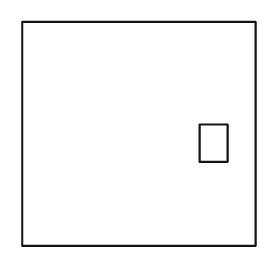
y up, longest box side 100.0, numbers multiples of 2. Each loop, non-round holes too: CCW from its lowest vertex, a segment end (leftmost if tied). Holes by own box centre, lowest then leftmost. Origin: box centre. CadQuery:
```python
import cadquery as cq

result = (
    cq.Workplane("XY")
    .moveTo(-50.0, -48.0)
    .lineTo(50.0, -48.0)
    .lineTo(50.0, 48.0)
    .lineTo(-50.0, 48.0)
    .close()
    .moveTo(26.0, -12.0)
    .lineTo(38.0, -12.0)
    .lineTo(38.0, 4.0)
    .lineTo(26.0, 4.0)
    .close()
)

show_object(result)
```